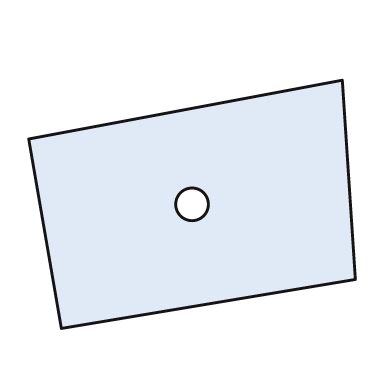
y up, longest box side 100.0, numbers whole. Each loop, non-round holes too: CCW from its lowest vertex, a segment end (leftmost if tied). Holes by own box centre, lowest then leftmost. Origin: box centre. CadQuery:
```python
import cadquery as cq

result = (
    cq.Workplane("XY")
    .moveTo(-40.0, -38.0)
    .lineTo(50.0, -23.0)
    .lineTo(46.0, 38.0)
    .lineTo(-50.0, 20.0)
    .close()
    .moveTo(0.0, 0.0)
    .circle(5.0)
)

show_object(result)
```